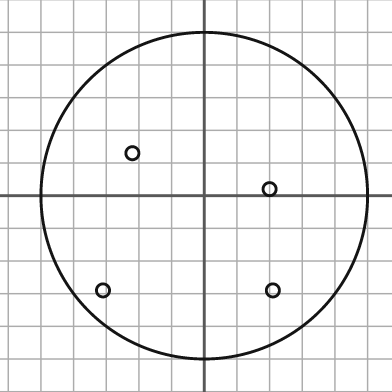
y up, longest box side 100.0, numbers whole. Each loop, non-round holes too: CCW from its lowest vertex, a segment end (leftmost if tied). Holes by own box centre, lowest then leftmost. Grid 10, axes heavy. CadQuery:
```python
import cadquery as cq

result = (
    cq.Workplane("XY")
    .moveTo(0.0, 0.0)
    .circle(50.0)
    .moveTo(-31.0, -29.0)
    .circle(2.0)
    .moveTo(21.0, -29.0)
    .circle(2.0)
    .moveTo(20.0, 2.0)
    .circle(2.0)
    .moveTo(-22.0, 13.0)
    .circle(2.0)
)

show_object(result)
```